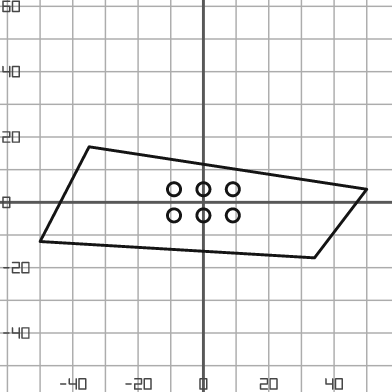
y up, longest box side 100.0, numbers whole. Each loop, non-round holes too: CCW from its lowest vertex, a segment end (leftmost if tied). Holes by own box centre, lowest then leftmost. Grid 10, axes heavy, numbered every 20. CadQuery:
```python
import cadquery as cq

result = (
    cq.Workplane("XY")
    .moveTo(34.0, -17.0)
    .lineTo(50.0, 4.0)
    .lineTo(-35.0, 17.0)
    .lineTo(-50.0, -12.0)
    .close()
    .moveTo(-9.0, -4.0)
    .circle(2.0)
    .moveTo(0.0, -4.0)
    .circle(2.0)
    .moveTo(9.0, -4.0)
    .circle(2.0)
    .moveTo(-9.0, 4.0)
    .circle(2.0)
    .moveTo(0.0, 4.0)
    .circle(2.0)
    .moveTo(9.0, 4.0)
    .circle(2.0)
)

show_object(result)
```